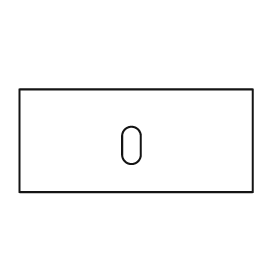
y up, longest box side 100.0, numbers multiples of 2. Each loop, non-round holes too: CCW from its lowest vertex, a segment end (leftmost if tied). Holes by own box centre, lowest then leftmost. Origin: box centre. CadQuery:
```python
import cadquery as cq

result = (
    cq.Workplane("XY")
    .moveTo(-50.0, -22.0)
    .lineTo(50.0, -22.0)
    .lineTo(50.0, 22.0)
    .lineTo(-50.0, 22.0)
    .close()
    .moveTo(-6.0, -6.0)
    .threePointArc((-2.0, -10.0), (2.0, -6.0))
    .lineTo(2.0, 2.0)
    .threePointArc((-2.0, 6.0), (-6.0, 2.0))
    .close()
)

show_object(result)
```